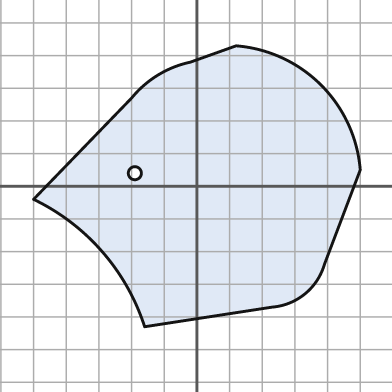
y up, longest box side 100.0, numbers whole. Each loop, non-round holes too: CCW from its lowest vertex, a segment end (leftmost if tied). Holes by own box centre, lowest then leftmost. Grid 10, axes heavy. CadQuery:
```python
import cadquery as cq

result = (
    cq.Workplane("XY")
    .moveTo(-16.0, -43.0)
    .lineTo(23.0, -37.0)
    .threePointArc((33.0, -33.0), (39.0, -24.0))
    .lineTo(50.0, 5.0)
    .threePointArc((38.0, 31.0), (12.0, 43.0))
    .lineTo(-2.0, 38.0)
    .threePointArc((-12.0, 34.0), (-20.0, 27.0))
    .lineTo(-50.0, -4.0)
    .threePointArc((-29.0, -20.0), (-16.0, -43.0))
    .close()
    .moveTo(-19.0, 4.0)
    .circle(2.0)
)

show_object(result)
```